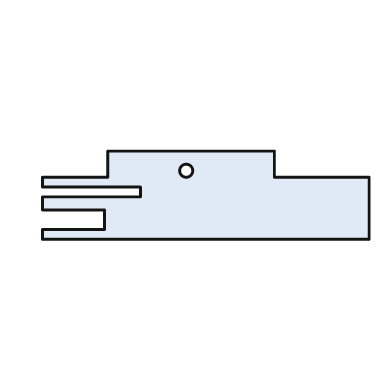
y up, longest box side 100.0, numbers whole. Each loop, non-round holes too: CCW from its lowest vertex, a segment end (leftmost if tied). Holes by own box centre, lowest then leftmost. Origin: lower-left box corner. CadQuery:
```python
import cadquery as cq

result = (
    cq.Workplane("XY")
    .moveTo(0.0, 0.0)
    .lineTo(100.0, 0.0)
    .lineTo(100.0, 19.0)
    .lineTo(71.0, 19.0)
    .lineTo(71.0, 27.0)
    .lineTo(20.0, 27.0)
    .lineTo(20.0, 19.0)
    .lineTo(0.0, 19.0)
    .lineTo(0.0, 16.0)
    .lineTo(30.0, 16.0)
    .lineTo(30.0, 13.0)
    .lineTo(0.0, 13.0)
    .lineTo(0.0, 9.0)
    .lineTo(19.0, 9.0)
    .lineTo(19.0, 3.0)
    .lineTo(0.0, 3.0)
    .close()
    .moveTo(44.0, 21.0)
    .circle(2.0)
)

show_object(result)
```